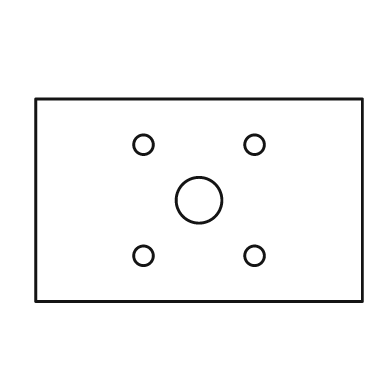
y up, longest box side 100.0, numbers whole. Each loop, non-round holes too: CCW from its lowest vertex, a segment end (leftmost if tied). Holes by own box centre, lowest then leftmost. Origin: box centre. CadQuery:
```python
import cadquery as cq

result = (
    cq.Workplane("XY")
    .moveTo(-50.0, -31.0)
    .lineTo(50.0, -31.0)
    .lineTo(50.0, 31.0)
    .lineTo(-50.0, 31.0)
    .close()
    .moveTo(-17.0, -17.0)
    .circle(3.0)
    .moveTo(17.0, -17.0)
    .circle(3.0)
    .moveTo(0.0, 0.0)
    .circle(7.0)
    .moveTo(-17.0, 17.0)
    .circle(3.0)
    .moveTo(17.0, 17.0)
    .circle(3.0)
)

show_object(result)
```